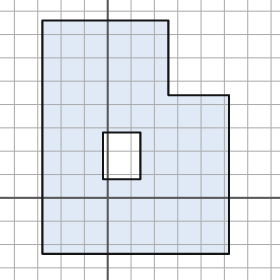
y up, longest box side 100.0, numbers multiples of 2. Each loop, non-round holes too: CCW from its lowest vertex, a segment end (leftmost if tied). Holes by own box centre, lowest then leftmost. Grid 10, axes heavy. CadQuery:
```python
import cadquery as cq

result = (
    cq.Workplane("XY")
    .moveTo(-28.0, -24.0)
    .lineTo(52.0, -24.0)
    .lineTo(52.0, 44.0)
    .lineTo(26.0, 44.0)
    .lineTo(26.0, 76.0)
    .lineTo(-28.0, 76.0)
    .close()
    .moveTo(-2.0, 8.0)
    .lineTo(14.0, 8.0)
    .lineTo(14.0, 28.0)
    .lineTo(-2.0, 28.0)
    .close()
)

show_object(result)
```